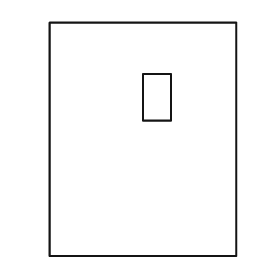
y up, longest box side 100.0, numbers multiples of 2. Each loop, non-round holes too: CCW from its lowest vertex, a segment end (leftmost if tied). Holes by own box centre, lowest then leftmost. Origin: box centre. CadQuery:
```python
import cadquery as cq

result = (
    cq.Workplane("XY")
    .moveTo(-40.0, -50.0)
    .lineTo(40.0, -50.0)
    .lineTo(40.0, 50.0)
    .lineTo(-40.0, 50.0)
    .close()
    .moveTo(0.0, 8.0)
    .lineTo(12.0, 8.0)
    .lineTo(12.0, 28.0)
    .lineTo(0.0, 28.0)
    .close()
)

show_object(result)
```